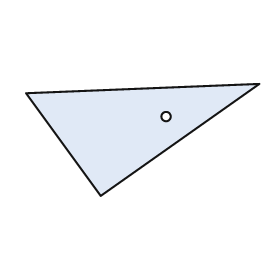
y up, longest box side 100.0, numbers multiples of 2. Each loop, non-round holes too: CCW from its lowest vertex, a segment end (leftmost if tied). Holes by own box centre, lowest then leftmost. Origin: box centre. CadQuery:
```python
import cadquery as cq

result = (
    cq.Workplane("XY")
    .moveTo(-18.0, -24.0)
    .lineTo(50.0, 24.0)
    .lineTo(-50.0, 20.0)
    .close()
    .moveTo(10.0, 10.0)
    .circle(2.0)
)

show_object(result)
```